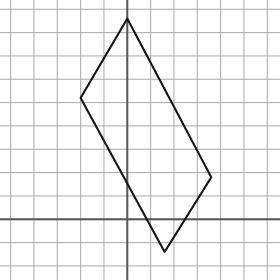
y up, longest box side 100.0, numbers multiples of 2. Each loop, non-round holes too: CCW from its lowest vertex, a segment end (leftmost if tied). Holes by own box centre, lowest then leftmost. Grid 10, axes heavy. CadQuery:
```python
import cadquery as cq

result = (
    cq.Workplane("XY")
    .moveTo(16.0, -14.0)
    .lineTo(36.0, 18.0)
    .lineTo(0.0, 86.0)
    .lineTo(-20.0, 52.0)
    .close()
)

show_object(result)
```